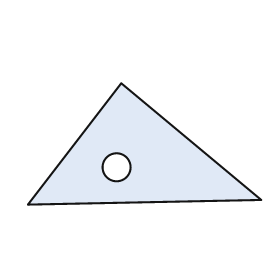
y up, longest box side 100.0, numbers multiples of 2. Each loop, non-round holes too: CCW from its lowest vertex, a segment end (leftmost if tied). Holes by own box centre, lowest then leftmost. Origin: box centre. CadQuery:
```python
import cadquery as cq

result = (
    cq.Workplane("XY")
    .moveTo(-50.0, -26.0)
    .lineTo(50.0, -24.0)
    .lineTo(-10.0, 26.0)
    .close()
    .moveTo(-12.0, -10.0)
    .circle(6.0)
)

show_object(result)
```